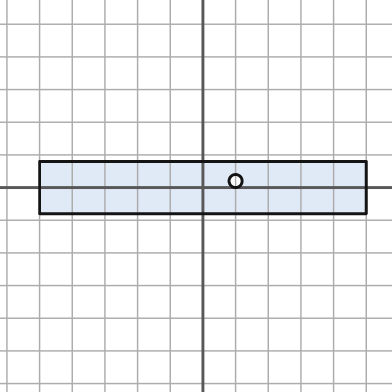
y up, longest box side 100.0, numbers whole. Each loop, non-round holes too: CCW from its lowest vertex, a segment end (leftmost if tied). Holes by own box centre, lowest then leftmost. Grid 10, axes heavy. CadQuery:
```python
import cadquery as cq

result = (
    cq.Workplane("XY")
    .moveTo(-50.0, -8.0)
    .lineTo(50.0, -8.0)
    .lineTo(50.0, 8.0)
    .lineTo(-50.0, 8.0)
    .close()
    .moveTo(10.0, 2.0)
    .circle(2.0)
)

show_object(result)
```